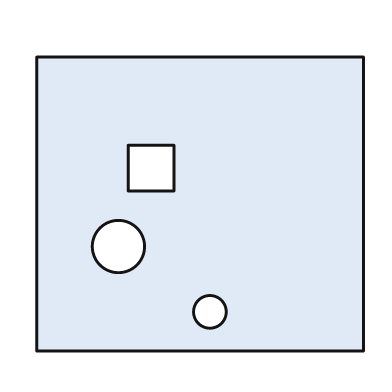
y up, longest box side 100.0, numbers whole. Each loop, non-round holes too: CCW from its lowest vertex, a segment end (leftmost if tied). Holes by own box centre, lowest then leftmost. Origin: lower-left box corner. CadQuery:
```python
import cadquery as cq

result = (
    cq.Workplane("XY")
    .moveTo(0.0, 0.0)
    .lineTo(100.0, 0.0)
    .lineTo(100.0, 90.0)
    .lineTo(0.0, 90.0)
    .close()
    .moveTo(53.0, 12.0)
    .circle(5.0)
    .moveTo(25.0, 32.0)
    .circle(8.0)
    .moveTo(28.0, 49.0)
    .lineTo(42.0, 49.0)
    .lineTo(42.0, 63.0)
    .lineTo(28.0, 63.0)
    .close()
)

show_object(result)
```